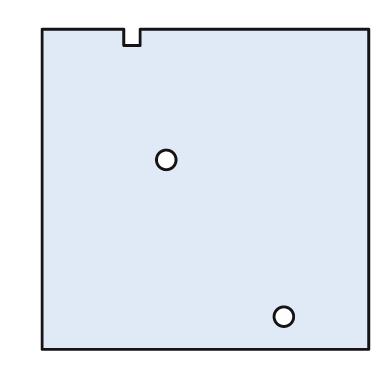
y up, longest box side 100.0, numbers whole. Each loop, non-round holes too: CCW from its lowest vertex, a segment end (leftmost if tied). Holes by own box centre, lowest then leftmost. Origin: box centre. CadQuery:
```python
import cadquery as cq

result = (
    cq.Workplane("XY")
    .moveTo(-50.0, -49.0)
    .lineTo(50.0, -49.0)
    .lineTo(50.0, 49.0)
    .lineTo(-20.0, 49.0)
    .lineTo(-20.0, 44.0)
    .lineTo(-25.0, 44.0)
    .lineTo(-25.0, 49.0)
    .lineTo(-50.0, 49.0)
    .close()
    .moveTo(24.0, -39.0)
    .circle(3.0)
    .moveTo(-12.0, 9.0)
    .circle(3.0)
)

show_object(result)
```